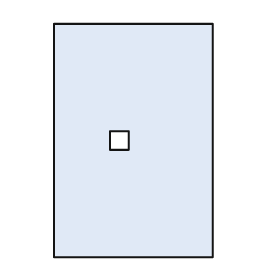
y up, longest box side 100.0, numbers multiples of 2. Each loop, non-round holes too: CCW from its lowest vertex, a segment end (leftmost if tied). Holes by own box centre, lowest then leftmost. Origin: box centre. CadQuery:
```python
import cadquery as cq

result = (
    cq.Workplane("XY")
    .moveTo(-34.0, -50.0)
    .lineTo(34.0, -50.0)
    .lineTo(34.0, 50.0)
    .lineTo(-34.0, 50.0)
    .close()
    .moveTo(-10.0, -4.0)
    .lineTo(-2.0, -4.0)
    .lineTo(-2.0, 4.0)
    .lineTo(-10.0, 4.0)
    .close()
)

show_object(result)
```